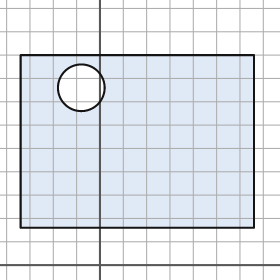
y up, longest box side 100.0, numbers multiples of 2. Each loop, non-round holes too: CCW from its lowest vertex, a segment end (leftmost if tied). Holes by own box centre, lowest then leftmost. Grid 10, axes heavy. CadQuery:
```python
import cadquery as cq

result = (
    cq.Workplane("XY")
    .moveTo(-34.0, 16.0)
    .lineTo(66.0, 16.0)
    .lineTo(66.0, 90.0)
    .lineTo(-34.0, 90.0)
    .close()
    .moveTo(-8.0, 76.0)
    .circle(10.0)
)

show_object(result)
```